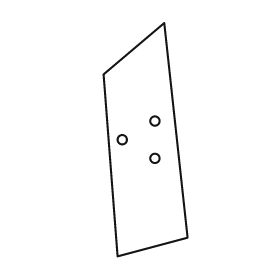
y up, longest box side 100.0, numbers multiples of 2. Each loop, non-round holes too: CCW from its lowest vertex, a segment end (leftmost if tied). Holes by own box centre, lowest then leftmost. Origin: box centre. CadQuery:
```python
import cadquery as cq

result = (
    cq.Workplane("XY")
    .moveTo(-12.0, -50.0)
    .lineTo(18.0, -42.0)
    .lineTo(8.0, 50.0)
    .lineTo(-18.0, 28.0)
    .close()
    .moveTo(4.0, -8.0)
    .circle(2.0)
    .moveTo(-10.0, 0.0)
    .circle(2.0)
    .moveTo(4.0, 8.0)
    .circle(2.0)
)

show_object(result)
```